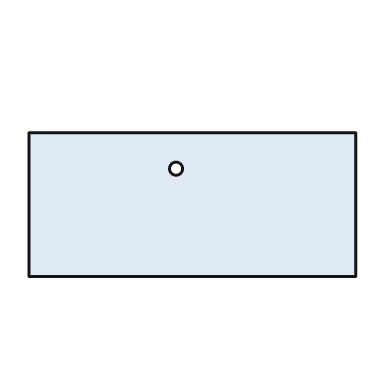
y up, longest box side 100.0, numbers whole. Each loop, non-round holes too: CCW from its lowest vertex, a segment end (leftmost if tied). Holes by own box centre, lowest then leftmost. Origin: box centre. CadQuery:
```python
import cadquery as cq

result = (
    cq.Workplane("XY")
    .moveTo(-50.0, -22.0)
    .lineTo(50.0, -22.0)
    .lineTo(50.0, 22.0)
    .lineTo(-50.0, 22.0)
    .close()
    .moveTo(-5.0, 11.0)
    .circle(2.0)
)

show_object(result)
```